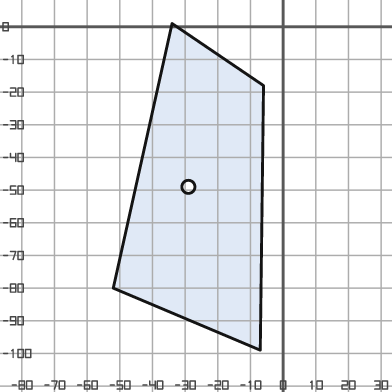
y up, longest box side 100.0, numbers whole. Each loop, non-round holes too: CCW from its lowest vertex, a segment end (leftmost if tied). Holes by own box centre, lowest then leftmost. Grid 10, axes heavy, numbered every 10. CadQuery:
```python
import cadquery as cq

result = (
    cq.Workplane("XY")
    .moveTo(-7.0, -99.0)
    .lineTo(-6.0, -18.0)
    .lineTo(-34.0, 1.0)
    .lineTo(-52.0, -80.0)
    .close()
    .moveTo(-29.0, -49.0)
    .circle(2.0)
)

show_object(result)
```